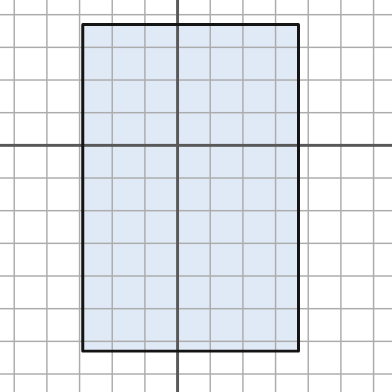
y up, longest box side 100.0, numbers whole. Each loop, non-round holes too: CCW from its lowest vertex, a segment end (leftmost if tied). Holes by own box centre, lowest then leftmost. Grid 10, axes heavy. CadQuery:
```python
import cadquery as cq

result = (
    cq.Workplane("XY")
    .moveTo(-29.0, -63.0)
    .lineTo(37.0, -63.0)
    .lineTo(37.0, 37.0)
    .lineTo(-29.0, 37.0)
    .close()
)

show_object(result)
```